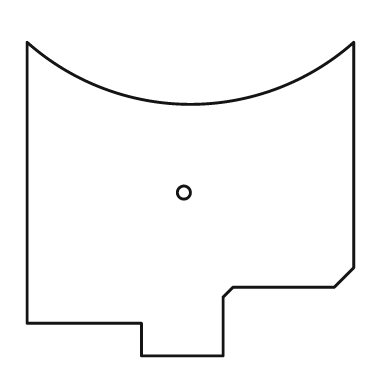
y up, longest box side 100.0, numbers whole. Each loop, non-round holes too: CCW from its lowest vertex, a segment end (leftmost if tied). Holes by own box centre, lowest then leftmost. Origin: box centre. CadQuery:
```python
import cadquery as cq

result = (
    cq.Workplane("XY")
    .moveTo(-15.0, -48.0)
    .lineTo(10.0, -48.0)
    .lineTo(10.0, -30.0)
    .lineTo(13.0, -27.0)
    .lineTo(44.0, -27.0)
    .lineTo(50.0, -21.0)
    .lineTo(50.0, 48.0)
    .threePointArc((0.0, 29.0), (-50.0, 48.0))
    .lineTo(-50.0, -38.0)
    .lineTo(-15.0, -38.0)
    .close()
    .moveTo(-2.0, 2.0)
    .circle(2.0)
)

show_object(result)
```